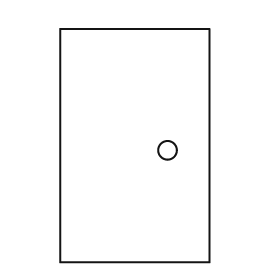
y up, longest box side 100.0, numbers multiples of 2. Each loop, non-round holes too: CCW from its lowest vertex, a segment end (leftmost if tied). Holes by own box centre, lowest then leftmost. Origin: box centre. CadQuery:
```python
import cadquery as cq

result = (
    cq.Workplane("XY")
    .moveTo(-32.0, -50.0)
    .lineTo(32.0, -50.0)
    .lineTo(32.0, 50.0)
    .lineTo(-32.0, 50.0)
    .close()
    .moveTo(14.0, -2.0)
    .circle(4.0)
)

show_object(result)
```